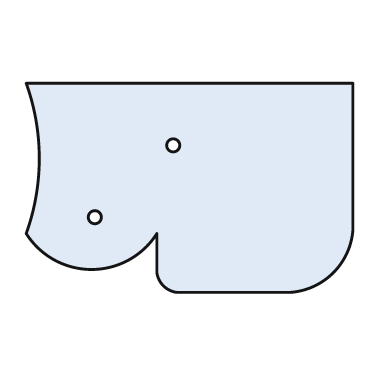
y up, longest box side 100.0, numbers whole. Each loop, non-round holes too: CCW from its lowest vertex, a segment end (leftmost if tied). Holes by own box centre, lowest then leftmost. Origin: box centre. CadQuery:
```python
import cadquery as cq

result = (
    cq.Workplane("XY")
    .moveTo(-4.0, -32.0)
    .lineTo(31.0, -32.0)
    .threePointArc((44.0, -26.0), (50.0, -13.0))
    .lineTo(50.0, 32.0)
    .lineTo(-50.0, 32.0)
    .threePointArc((-46.0, 9.0), (-50.0, -14.0))
    .threePointArc((-30.0, -25.0), (-10.0, -14.0))
    .lineTo(-10.0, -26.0)
    .threePointArc((-8.0, -30.0), (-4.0, -32.0))
    .close()
    .moveTo(-29.0, -9.0)
    .circle(2.0)
    .moveTo(-5.0, 13.0)
    .circle(2.0)
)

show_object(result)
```